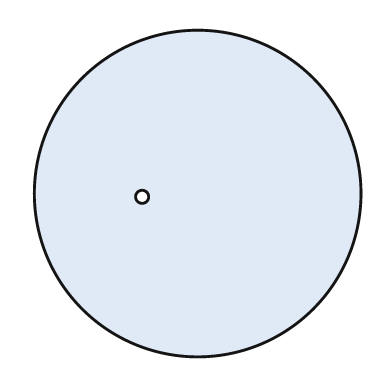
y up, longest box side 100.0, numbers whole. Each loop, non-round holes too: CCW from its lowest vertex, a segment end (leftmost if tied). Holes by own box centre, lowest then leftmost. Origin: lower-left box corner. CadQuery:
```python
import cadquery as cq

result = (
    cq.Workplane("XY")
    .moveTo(50.0, 50.0)
    .circle(50.0)
    .moveTo(33.0, 49.0)
    .circle(2.0)
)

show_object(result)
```